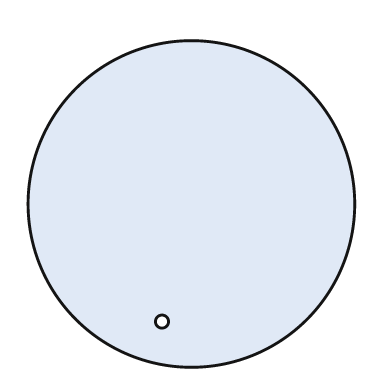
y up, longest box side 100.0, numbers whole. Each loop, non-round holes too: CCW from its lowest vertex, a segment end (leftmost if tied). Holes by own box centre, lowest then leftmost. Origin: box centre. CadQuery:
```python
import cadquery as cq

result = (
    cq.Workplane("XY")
    .moveTo(0.0, 0.0)
    .circle(50.0)
    .moveTo(-9.0, -36.0)
    .circle(2.0)
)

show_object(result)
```